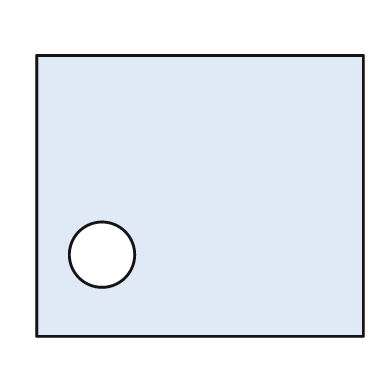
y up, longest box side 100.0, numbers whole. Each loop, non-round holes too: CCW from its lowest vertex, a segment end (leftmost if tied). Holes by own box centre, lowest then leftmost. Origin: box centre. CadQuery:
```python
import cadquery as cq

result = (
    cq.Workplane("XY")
    .moveTo(-50.0, -43.0)
    .lineTo(50.0, -43.0)
    .lineTo(50.0, 43.0)
    .lineTo(-50.0, 43.0)
    .close()
    .moveTo(-30.0, -18.0)
    .circle(10.0)
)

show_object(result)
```